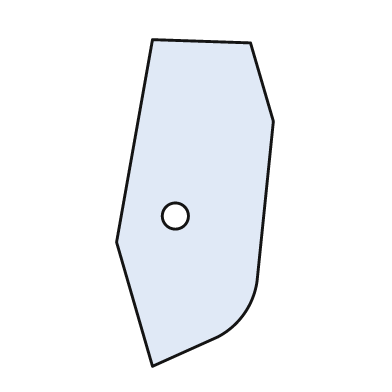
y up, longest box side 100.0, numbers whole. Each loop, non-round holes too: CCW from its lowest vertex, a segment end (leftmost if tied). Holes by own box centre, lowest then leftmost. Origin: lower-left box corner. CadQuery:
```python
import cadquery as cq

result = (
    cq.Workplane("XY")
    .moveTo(11.0, 0.0)
    .lineTo(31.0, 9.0)
    .threePointArc((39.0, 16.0), (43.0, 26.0))
    .lineTo(48.0, 75.0)
    .lineTo(41.0, 99.0)
    .lineTo(11.0, 100.0)
    .lineTo(0.0, 38.0)
    .close()
    .moveTo(18.0, 46.0)
    .circle(4.0)
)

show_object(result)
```